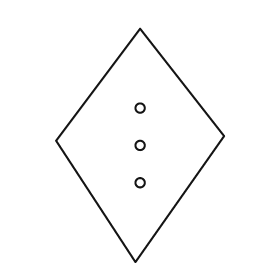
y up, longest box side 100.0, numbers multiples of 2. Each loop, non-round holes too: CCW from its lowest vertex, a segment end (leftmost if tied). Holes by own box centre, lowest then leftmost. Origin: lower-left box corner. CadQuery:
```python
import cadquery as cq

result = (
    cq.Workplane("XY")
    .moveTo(34.0, 0.0)
    .lineTo(72.0, 54.0)
    .lineTo(36.0, 100.0)
    .lineTo(0.0, 52.0)
    .close()
    .moveTo(36.0, 34.0)
    .circle(2.0)
    .moveTo(36.0, 50.0)
    .circle(2.0)
    .moveTo(36.0, 66.0)
    .circle(2.0)
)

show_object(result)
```